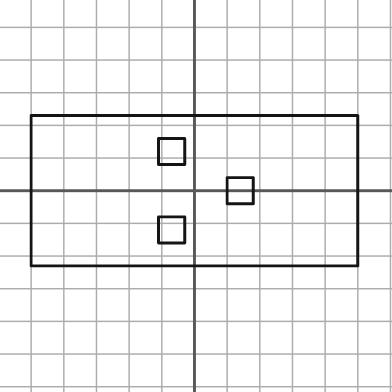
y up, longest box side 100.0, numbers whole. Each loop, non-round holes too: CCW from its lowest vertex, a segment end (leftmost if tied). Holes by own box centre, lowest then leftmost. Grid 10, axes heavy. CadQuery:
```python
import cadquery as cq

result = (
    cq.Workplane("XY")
    .moveTo(-50.0, -23.0)
    .lineTo(50.0, -23.0)
    .lineTo(50.0, 23.0)
    .lineTo(-50.0, 23.0)
    .close()
    .moveTo(-11.0, -16.0)
    .lineTo(-3.0, -16.0)
    .lineTo(-3.0, -8.0)
    .lineTo(-11.0, -8.0)
    .close()
    .moveTo(10.0, -4.0)
    .lineTo(18.0, -4.0)
    .lineTo(18.0, 4.0)
    .lineTo(10.0, 4.0)
    .close()
    .moveTo(-11.0, 8.0)
    .lineTo(-3.0, 8.0)
    .lineTo(-3.0, 16.0)
    .lineTo(-11.0, 16.0)
    .close()
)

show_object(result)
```